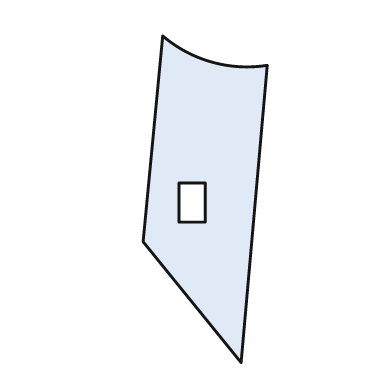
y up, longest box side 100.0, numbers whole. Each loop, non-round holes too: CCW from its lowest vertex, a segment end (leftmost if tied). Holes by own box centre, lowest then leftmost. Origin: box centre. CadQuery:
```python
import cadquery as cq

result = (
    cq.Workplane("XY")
    .moveTo(11.0, -50.0)
    .lineTo(19.0, 41.0)
    .threePointArc((2.0, 42.0), (-13.0, 50.0))
    .lineTo(-19.0, -13.0)
    .close()
    .moveTo(-8.0, -7.0)
    .lineTo(0.0, -7.0)
    .lineTo(0.0, 5.0)
    .lineTo(-8.0, 5.0)
    .close()
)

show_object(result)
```